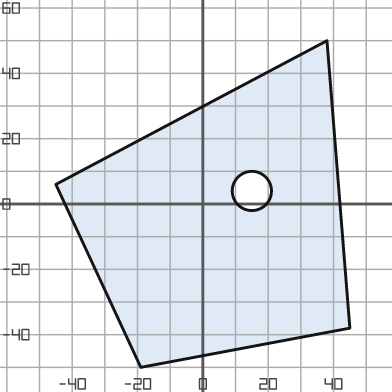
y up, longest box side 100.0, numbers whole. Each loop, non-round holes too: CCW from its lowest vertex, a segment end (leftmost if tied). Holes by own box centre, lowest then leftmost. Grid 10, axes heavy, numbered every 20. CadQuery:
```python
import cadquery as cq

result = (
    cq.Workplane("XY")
    .moveTo(-19.0, -50.0)
    .lineTo(45.0, -38.0)
    .lineTo(38.0, 50.0)
    .lineTo(-45.0, 6.0)
    .close()
    .moveTo(15.0, 4.0)
    .circle(6.0)
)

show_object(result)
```